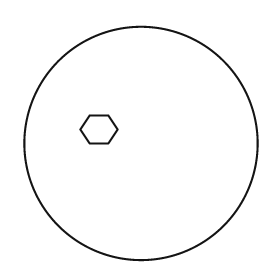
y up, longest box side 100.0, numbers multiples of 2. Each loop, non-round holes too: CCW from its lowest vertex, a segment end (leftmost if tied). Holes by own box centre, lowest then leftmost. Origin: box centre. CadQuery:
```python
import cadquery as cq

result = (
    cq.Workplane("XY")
    .moveTo(0.0, 0.0)
    .circle(50.0)
    .moveTo(-22.0, 0.0)
    .lineTo(-14.0, 0.0)
    .lineTo(-10.0, 6.0)
    .lineTo(-14.0, 12.0)
    .lineTo(-22.0, 12.0)
    .lineTo(-26.0, 6.0)
    .close()
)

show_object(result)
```